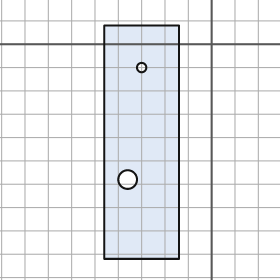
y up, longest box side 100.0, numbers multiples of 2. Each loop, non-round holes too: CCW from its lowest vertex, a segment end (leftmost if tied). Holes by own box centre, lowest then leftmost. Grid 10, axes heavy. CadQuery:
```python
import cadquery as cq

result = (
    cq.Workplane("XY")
    .moveTo(-46.0, -92.0)
    .lineTo(-14.0, -92.0)
    .lineTo(-14.0, 8.0)
    .lineTo(-46.0, 8.0)
    .close()
    .moveTo(-36.0, -58.0)
    .circle(4.0)
    .moveTo(-30.0, -10.0)
    .circle(2.0)
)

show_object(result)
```